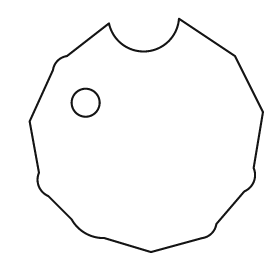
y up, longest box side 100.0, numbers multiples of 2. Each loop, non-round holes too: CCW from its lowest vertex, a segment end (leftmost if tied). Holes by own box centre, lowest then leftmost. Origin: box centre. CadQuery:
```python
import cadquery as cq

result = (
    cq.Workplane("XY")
    .moveTo(2.0, -50.0)
    .lineTo(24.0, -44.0)
    .threePointArc((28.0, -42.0), (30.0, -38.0))
    .lineTo(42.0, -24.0)
    .threePointArc((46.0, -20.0), (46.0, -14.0))
    .lineTo(50.0, 10.0)
    .lineTo(38.0, 34.0)
    .lineTo(14.0, 50.0)
    .threePointArc((0.0, 36.0), (-16.0, 48.0))
    .lineTo(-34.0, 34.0)
    .threePointArc((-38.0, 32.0), (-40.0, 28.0))
    .lineTo(-50.0, 6.0)
    .lineTo(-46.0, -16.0)
    .threePointArc((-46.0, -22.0), (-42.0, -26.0))
    .lineTo(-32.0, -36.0)
    .threePointArc((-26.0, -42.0), (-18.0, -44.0))
    .close()
    .moveTo(-26.0, 14.0)
    .circle(6.0)
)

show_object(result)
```